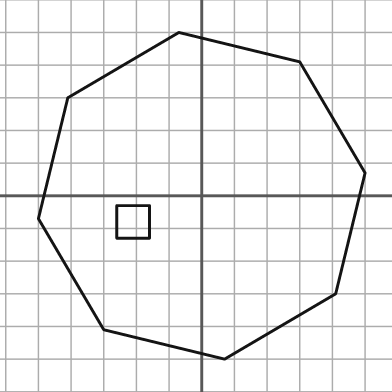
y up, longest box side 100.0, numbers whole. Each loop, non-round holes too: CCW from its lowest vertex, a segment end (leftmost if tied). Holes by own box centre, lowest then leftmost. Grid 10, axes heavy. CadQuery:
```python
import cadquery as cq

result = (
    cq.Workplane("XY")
    .moveTo(7.0, -50.0)
    .lineTo(41.0, -30.0)
    .lineTo(50.0, 7.0)
    .lineTo(30.0, 41.0)
    .lineTo(-7.0, 50.0)
    .lineTo(-41.0, 30.0)
    .lineTo(-50.0, -7.0)
    .lineTo(-30.0, -41.0)
    .close()
    .moveTo(-26.0, -13.0)
    .lineTo(-16.0, -13.0)
    .lineTo(-16.0, -3.0)
    .lineTo(-26.0, -3.0)
    .close()
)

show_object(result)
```